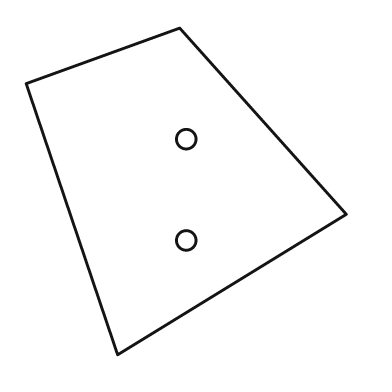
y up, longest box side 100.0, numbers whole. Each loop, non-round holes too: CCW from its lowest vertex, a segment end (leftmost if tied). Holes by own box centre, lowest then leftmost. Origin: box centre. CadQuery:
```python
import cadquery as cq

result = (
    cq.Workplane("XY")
    .moveTo(-21.0, -50.0)
    .lineTo(49.0, -7.0)
    .lineTo(-2.0, 50.0)
    .lineTo(-49.0, 33.0)
    .close()
    .moveTo(0.0, -15.0)
    .circle(3.0)
    .moveTo(0.0, 16.0)
    .circle(3.0)
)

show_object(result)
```